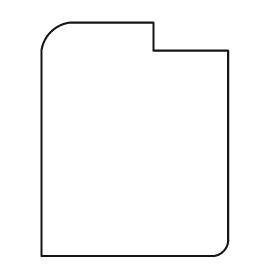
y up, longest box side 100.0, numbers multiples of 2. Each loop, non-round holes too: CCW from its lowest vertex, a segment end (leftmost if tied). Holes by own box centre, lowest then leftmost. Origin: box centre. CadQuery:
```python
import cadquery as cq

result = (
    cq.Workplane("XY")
    .moveTo(-40.0, -50.0)
    .lineTo(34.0, -50.0)
    .threePointArc((38.0, -48.0), (40.0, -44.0))
    .lineTo(40.0, 38.0)
    .lineTo(8.0, 38.0)
    .lineTo(8.0, 50.0)
    .lineTo(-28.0, 50.0)
    .threePointArc((-36.0, 46.0), (-40.0, 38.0))
    .close()
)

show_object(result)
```